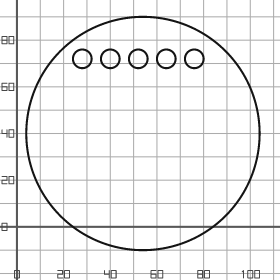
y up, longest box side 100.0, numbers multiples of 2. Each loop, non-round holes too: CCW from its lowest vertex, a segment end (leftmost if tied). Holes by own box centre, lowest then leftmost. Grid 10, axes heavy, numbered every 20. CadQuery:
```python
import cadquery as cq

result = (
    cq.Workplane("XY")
    .moveTo(54.0, 40.0)
    .circle(50.0)
    .moveTo(28.0, 72.0)
    .circle(4.0)
    .moveTo(40.0, 72.0)
    .circle(4.0)
    .moveTo(52.0, 72.0)
    .circle(4.0)
    .moveTo(64.0, 72.0)
    .circle(4.0)
    .moveTo(76.0, 72.0)
    .circle(4.0)
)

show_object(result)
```